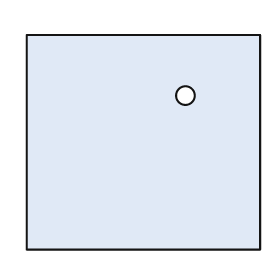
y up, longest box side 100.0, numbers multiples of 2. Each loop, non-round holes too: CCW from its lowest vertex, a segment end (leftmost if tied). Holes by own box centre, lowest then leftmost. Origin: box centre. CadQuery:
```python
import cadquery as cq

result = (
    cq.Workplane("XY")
    .moveTo(-50.0, -46.0)
    .lineTo(50.0, -46.0)
    .lineTo(50.0, 46.0)
    .lineTo(-50.0, 46.0)
    .close()
    .moveTo(18.0, 20.0)
    .circle(4.0)
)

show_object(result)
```